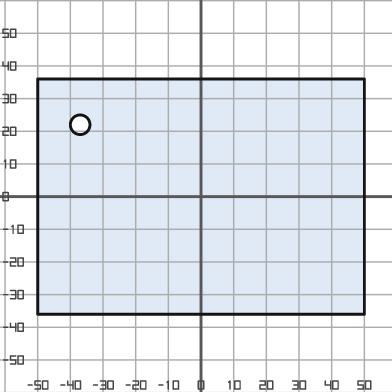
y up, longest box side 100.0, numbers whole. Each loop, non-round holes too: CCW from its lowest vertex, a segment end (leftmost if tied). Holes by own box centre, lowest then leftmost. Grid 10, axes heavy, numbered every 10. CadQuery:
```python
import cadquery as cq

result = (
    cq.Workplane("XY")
    .moveTo(-50.0, -36.0)
    .lineTo(50.0, -36.0)
    .lineTo(50.0, 36.0)
    .lineTo(-50.0, 36.0)
    .close()
    .moveTo(-37.0, 22.0)
    .circle(3.0)
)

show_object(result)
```